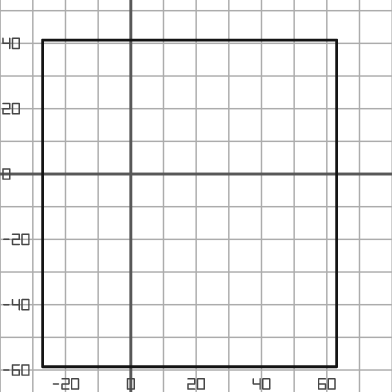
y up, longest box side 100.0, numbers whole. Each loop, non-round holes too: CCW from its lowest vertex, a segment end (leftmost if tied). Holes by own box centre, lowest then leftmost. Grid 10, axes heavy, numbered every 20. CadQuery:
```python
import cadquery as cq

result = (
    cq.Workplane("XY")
    .moveTo(-27.0, -59.0)
    .lineTo(63.0, -59.0)
    .lineTo(63.0, 41.0)
    .lineTo(-27.0, 41.0)
    .close()
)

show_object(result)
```